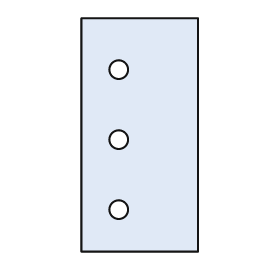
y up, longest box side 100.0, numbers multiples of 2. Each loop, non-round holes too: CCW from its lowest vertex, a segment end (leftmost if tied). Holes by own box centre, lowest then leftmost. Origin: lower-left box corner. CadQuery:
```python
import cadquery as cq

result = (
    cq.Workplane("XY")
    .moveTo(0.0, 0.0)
    .lineTo(50.0, 0.0)
    .lineTo(50.0, 100.0)
    .lineTo(0.0, 100.0)
    .close()
    .moveTo(16.0, 18.0)
    .circle(4.0)
    .moveTo(16.0, 48.0)
    .circle(4.0)
    .moveTo(16.0, 78.0)
    .circle(4.0)
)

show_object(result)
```